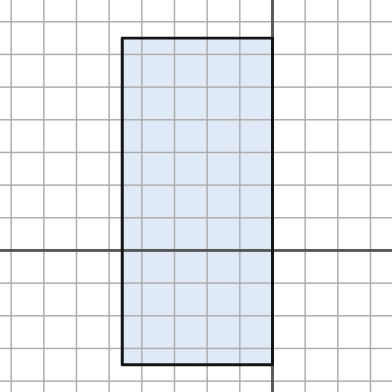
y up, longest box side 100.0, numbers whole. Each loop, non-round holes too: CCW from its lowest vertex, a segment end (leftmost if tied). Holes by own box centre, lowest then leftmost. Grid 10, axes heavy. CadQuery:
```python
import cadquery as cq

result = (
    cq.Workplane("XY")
    .moveTo(-46.0, -35.0)
    .lineTo(0.0, -35.0)
    .lineTo(0.0, 65.0)
    .lineTo(-46.0, 65.0)
    .close()
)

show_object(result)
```